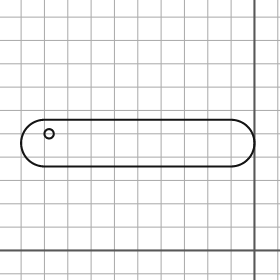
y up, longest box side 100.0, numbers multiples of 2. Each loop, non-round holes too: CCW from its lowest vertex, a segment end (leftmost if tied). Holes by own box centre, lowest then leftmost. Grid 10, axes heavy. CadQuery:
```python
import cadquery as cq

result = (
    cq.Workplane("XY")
    .moveTo(-90.0, 36.0)
    .lineTo(-10.0, 36.0)
    .threePointArc((0.0, 46.0), (-10.0, 56.0))
    .lineTo(-90.0, 56.0)
    .threePointArc((-100.0, 46.0), (-90.0, 36.0))
    .close()
    .moveTo(-88.0, 50.0)
    .circle(2.0)
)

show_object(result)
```